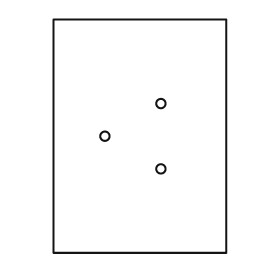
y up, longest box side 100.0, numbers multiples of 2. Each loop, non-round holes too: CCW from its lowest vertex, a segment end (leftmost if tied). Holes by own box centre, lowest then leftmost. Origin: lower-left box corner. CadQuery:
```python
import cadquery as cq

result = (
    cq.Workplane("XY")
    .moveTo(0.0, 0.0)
    .lineTo(74.0, 0.0)
    .lineTo(74.0, 100.0)
    .lineTo(0.0, 100.0)
    .close()
    .moveTo(46.0, 36.0)
    .circle(2.0)
    .moveTo(22.0, 50.0)
    .circle(2.0)
    .moveTo(46.0, 64.0)
    .circle(2.0)
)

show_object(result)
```